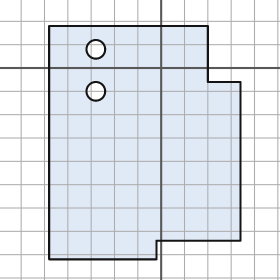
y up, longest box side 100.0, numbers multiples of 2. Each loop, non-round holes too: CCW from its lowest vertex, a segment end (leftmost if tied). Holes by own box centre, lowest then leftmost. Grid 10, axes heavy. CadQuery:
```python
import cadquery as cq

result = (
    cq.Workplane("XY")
    .moveTo(-48.0, -82.0)
    .lineTo(-2.0, -82.0)
    .lineTo(-2.0, -74.0)
    .lineTo(34.0, -74.0)
    .lineTo(34.0, -6.0)
    .lineTo(20.0, -6.0)
    .lineTo(20.0, 18.0)
    .lineTo(-48.0, 18.0)
    .close()
    .moveTo(-28.0, -10.0)
    .circle(4.0)
    .moveTo(-28.0, 8.0)
    .circle(4.0)
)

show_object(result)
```